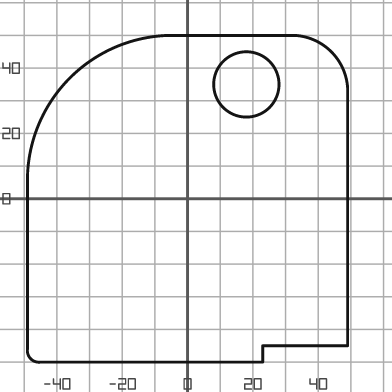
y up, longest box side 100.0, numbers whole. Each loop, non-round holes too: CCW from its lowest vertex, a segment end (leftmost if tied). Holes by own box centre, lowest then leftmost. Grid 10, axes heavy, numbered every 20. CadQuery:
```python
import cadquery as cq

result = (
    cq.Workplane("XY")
    .moveTo(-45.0, -50.0)
    .lineTo(23.0, -50.0)
    .lineTo(23.0, -45.0)
    .lineTo(49.0, -45.0)
    .lineTo(49.0, 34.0)
    .threePointArc((44.0, 45.0), (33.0, 50.0))
    .lineTo(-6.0, 50.0)
    .threePointArc((-36.0, 37.0), (-49.0, 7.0))
    .lineTo(-49.0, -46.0)
    .threePointArc((-48.0, -49.0), (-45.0, -50.0))
    .close()
    .moveTo(18.0, 35.0)
    .circle(10.0)
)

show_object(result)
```